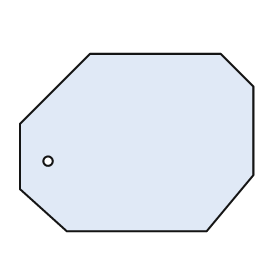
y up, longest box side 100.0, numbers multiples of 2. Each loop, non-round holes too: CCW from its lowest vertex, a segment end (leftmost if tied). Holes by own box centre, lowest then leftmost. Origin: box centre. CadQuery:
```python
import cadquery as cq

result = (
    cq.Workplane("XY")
    .moveTo(-30.0, -38.0)
    .lineTo(30.0, -38.0)
    .lineTo(50.0, -14.0)
    .lineTo(50.0, 24.0)
    .lineTo(36.0, 38.0)
    .lineTo(-20.0, 38.0)
    .lineTo(-50.0, 8.0)
    .lineTo(-50.0, -20.0)
    .close()
    .moveTo(-38.0, -8.0)
    .circle(2.0)
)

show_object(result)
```